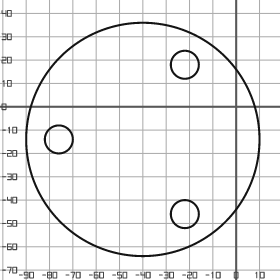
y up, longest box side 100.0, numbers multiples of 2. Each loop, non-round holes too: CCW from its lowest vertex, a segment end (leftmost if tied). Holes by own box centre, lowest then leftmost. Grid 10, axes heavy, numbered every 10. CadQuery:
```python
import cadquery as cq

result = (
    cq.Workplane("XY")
    .moveTo(-40.0, -14.0)
    .circle(50.0)
    .moveTo(-22.0, -46.0)
    .circle(6.0)
    .moveTo(-76.0, -14.0)
    .circle(6.0)
    .moveTo(-22.0, 18.0)
    .circle(6.0)
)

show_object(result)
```